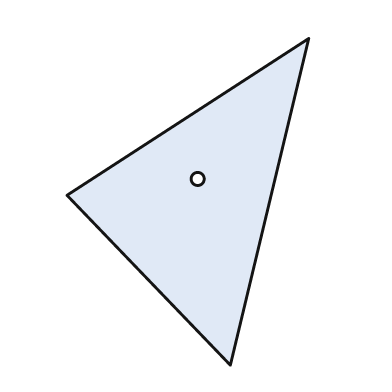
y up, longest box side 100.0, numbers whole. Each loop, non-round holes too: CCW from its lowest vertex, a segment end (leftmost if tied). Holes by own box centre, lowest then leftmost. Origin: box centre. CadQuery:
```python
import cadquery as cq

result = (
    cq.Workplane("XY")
    .moveTo(13.0, -50.0)
    .lineTo(37.0, 50.0)
    .lineTo(-37.0, 2.0)
    .close()
    .moveTo(3.0, 7.0)
    .circle(2.0)
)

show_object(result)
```